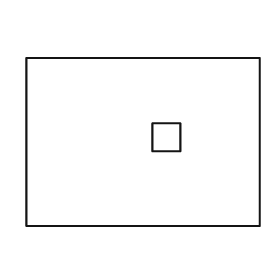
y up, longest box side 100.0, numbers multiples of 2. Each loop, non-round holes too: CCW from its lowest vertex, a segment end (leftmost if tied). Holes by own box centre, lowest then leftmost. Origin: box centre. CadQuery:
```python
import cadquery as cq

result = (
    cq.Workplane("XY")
    .moveTo(-50.0, -36.0)
    .lineTo(50.0, -36.0)
    .lineTo(50.0, 36.0)
    .lineTo(-50.0, 36.0)
    .close()
    .moveTo(4.0, -4.0)
    .lineTo(16.0, -4.0)
    .lineTo(16.0, 8.0)
    .lineTo(4.0, 8.0)
    .close()
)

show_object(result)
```